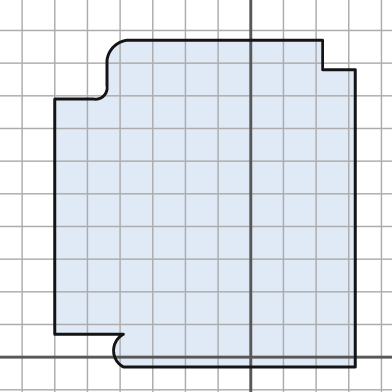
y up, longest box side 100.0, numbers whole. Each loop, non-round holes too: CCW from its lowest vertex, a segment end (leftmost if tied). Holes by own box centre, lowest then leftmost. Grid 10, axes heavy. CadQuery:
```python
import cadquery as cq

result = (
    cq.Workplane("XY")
    .moveTo(-39.0, -3.0)
    .lineTo(32.0, -3.0)
    .lineTo(32.0, 88.0)
    .lineTo(22.0, 88.0)
    .lineTo(22.0, 97.0)
    .lineTo(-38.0, 97.0)
    .threePointArc((-42.0, 95.0), (-44.0, 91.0))
    .lineTo(-44.0, 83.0)
    .threePointArc((-45.0, 80.0), (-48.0, 79.0))
    .lineTo(-60.0, 79.0)
    .lineTo(-60.0, 7.0)
    .lineTo(-39.0, 7.0)
    .threePointArc((-42.0, 2.0), (-39.0, -3.0))
    .close()
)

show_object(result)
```